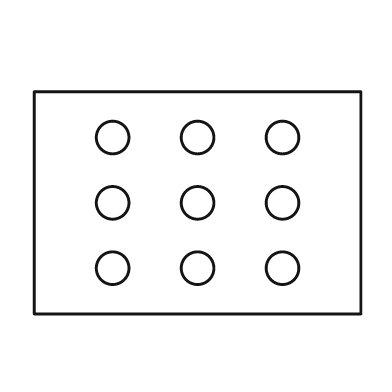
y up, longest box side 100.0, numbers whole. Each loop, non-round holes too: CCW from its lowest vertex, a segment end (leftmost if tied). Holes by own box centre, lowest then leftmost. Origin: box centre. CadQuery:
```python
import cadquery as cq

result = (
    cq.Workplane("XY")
    .moveTo(-50.0, -34.0)
    .lineTo(50.0, -34.0)
    .lineTo(50.0, 34.0)
    .lineTo(-50.0, 34.0)
    .close()
    .moveTo(-26.0, -20.0)
    .circle(5.0)
    .moveTo(0.0, -20.0)
    .circle(5.0)
    .moveTo(26.0, -20.0)
    .circle(5.0)
    .moveTo(-26.0, 0.0)
    .circle(5.0)
    .moveTo(0.0, 0.0)
    .circle(5.0)
    .moveTo(26.0, 0.0)
    .circle(5.0)
    .moveTo(-26.0, 20.0)
    .circle(5.0)
    .moveTo(0.0, 20.0)
    .circle(5.0)
    .moveTo(26.0, 20.0)
    .circle(5.0)
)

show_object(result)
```